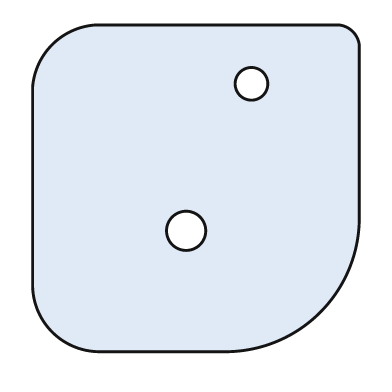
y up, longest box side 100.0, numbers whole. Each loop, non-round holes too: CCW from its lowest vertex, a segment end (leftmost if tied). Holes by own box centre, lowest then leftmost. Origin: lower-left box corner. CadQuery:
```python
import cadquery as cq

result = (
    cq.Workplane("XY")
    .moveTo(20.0, 0.0)
    .lineTo(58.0, 0.0)
    .threePointArc((88.0, 12.0), (100.0, 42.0))
    .lineTo(100.0, 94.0)
    .threePointArc((98.0, 98.0), (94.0, 100.0))
    .lineTo(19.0, 100.0)
    .threePointArc((6.0, 94.0), (0.0, 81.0))
    .lineTo(0.0, 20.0)
    .threePointArc((6.0, 6.0), (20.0, 0.0))
    .close()
    .moveTo(47.0, 37.0)
    .circle(6.0)
    .moveTo(67.0, 82.0)
    .circle(5.0)
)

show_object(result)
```